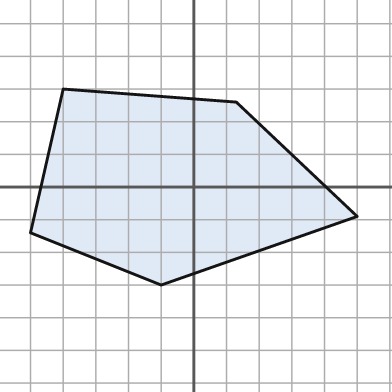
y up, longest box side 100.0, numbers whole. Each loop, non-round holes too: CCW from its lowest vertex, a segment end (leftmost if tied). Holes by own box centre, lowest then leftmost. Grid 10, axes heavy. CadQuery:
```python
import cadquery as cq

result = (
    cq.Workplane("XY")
    .moveTo(-10.0, -30.0)
    .lineTo(50.0, -9.0)
    .lineTo(13.0, 26.0)
    .lineTo(-40.0, 30.0)
    .lineTo(-50.0, -14.0)
    .close()
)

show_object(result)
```